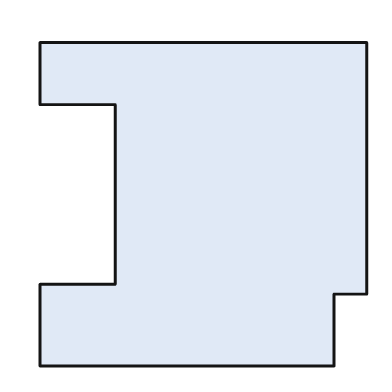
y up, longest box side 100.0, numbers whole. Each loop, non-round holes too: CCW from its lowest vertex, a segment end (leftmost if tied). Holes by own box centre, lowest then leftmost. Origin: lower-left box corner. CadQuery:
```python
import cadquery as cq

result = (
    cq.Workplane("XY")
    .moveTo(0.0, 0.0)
    .lineTo(90.0, 0.0)
    .lineTo(90.0, 22.0)
    .lineTo(100.0, 22.0)
    .lineTo(100.0, 99.0)
    .lineTo(0.0, 99.0)
    .lineTo(0.0, 80.0)
    .lineTo(23.0, 80.0)
    .lineTo(23.0, 25.0)
    .lineTo(0.0, 25.0)
    .close()
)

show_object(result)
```